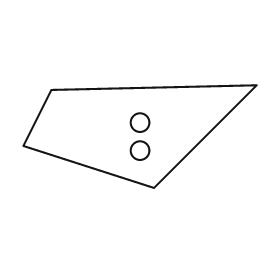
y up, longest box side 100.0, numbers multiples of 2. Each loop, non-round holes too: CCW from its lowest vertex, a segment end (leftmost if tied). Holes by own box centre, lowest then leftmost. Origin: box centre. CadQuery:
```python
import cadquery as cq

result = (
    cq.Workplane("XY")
    .moveTo(6.0, -22.0)
    .lineTo(50.0, 22.0)
    .lineTo(-38.0, 20.0)
    .lineTo(-50.0, -4.0)
    .close()
    .moveTo(0.0, -6.0)
    .circle(4.0)
    .moveTo(0.0, 6.0)
    .circle(4.0)
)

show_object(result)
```